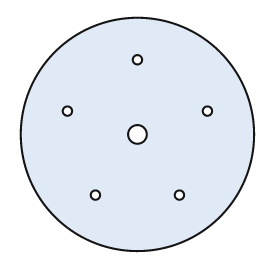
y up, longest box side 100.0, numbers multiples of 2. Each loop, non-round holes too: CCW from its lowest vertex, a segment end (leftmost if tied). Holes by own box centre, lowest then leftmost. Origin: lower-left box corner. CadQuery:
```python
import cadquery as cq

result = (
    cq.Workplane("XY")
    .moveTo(50.0, 50.0)
    .circle(50.0)
    .moveTo(32.0, 24.0)
    .circle(2.0)
    .moveTo(68.0, 24.0)
    .circle(2.0)
    .moveTo(50.0, 50.0)
    .circle(4.0)
    .moveTo(20.0, 60.0)
    .circle(2.0)
    .moveTo(80.0, 60.0)
    .circle(2.0)
    .moveTo(50.0, 82.0)
    .circle(2.0)
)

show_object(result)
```